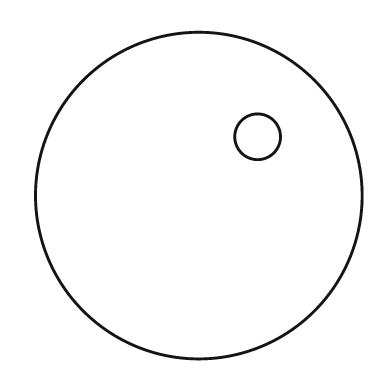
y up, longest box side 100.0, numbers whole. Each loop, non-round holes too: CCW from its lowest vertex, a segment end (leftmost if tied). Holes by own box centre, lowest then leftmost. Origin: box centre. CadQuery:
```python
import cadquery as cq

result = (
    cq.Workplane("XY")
    .moveTo(0.0, 0.0)
    .circle(50.0)
    .moveTo(18.0, 18.0)
    .circle(7.0)
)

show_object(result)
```